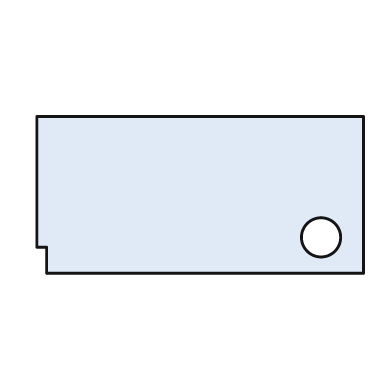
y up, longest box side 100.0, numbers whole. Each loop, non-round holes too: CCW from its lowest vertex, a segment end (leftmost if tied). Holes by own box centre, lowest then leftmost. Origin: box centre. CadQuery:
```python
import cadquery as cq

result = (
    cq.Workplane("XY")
    .moveTo(-47.0, -24.0)
    .lineTo(50.0, -24.0)
    .lineTo(50.0, 24.0)
    .lineTo(-50.0, 24.0)
    .lineTo(-50.0, -16.0)
    .lineTo(-47.0, -16.0)
    .close()
    .moveTo(37.0, -13.0)
    .circle(6.0)
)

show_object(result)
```